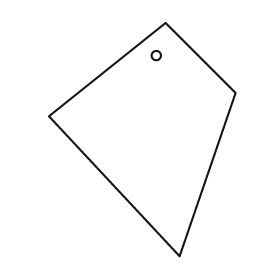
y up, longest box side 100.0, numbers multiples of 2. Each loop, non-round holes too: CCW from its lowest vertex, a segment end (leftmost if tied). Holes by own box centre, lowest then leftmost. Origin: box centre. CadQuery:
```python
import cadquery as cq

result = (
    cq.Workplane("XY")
    .moveTo(16.0, -50.0)
    .lineTo(40.0, 20.0)
    .lineTo(10.0, 50.0)
    .lineTo(-40.0, 10.0)
    .close()
    .moveTo(6.0, 36.0)
    .circle(2.0)
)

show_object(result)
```